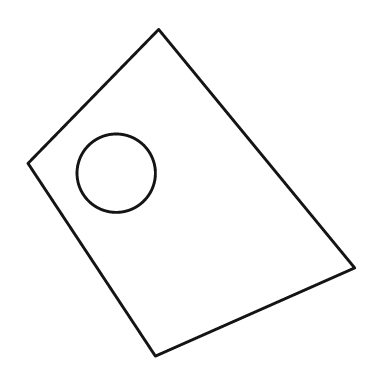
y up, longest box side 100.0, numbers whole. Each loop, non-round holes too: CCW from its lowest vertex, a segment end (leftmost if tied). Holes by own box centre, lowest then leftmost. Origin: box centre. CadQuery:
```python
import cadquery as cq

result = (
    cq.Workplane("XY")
    .moveTo(-11.0, -50.0)
    .lineTo(50.0, -23.0)
    .lineTo(-10.0, 50.0)
    .lineTo(-50.0, 9.0)
    .close()
    .moveTo(-23.0, 6.0)
    .circle(12.0)
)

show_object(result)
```